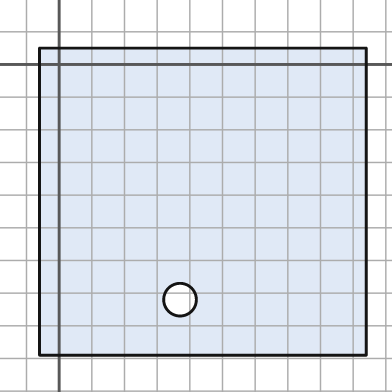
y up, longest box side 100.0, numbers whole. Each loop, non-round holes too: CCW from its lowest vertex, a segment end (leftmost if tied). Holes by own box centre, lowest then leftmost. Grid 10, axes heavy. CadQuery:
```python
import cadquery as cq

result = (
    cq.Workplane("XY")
    .moveTo(-6.0, -89.0)
    .lineTo(94.0, -89.0)
    .lineTo(94.0, 5.0)
    .lineTo(-6.0, 5.0)
    .close()
    .moveTo(37.0, -72.0)
    .circle(5.0)
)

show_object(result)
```